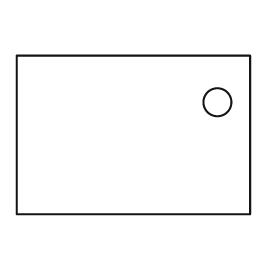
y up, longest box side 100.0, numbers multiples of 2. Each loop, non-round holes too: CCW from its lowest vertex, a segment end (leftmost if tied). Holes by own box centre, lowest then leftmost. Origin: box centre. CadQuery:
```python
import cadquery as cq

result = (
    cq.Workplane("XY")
    .moveTo(-50.0, -34.0)
    .lineTo(50.0, -34.0)
    .lineTo(50.0, 34.0)
    .lineTo(-50.0, 34.0)
    .close()
    .moveTo(36.0, 14.0)
    .circle(6.0)
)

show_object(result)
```